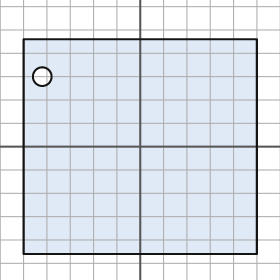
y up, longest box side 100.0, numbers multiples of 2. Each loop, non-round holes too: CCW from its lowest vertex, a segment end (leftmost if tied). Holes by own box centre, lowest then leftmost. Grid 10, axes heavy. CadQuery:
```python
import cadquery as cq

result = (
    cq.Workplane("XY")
    .moveTo(-50.0, -46.0)
    .lineTo(50.0, -46.0)
    .lineTo(50.0, 46.0)
    .lineTo(-50.0, 46.0)
    .close()
    .moveTo(-42.0, 30.0)
    .circle(4.0)
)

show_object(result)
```